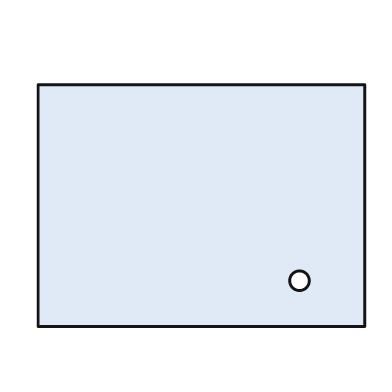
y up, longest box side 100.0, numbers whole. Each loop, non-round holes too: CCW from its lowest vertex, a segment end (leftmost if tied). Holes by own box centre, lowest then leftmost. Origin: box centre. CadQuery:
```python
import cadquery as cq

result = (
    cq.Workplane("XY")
    .moveTo(-50.0, -37.0)
    .lineTo(50.0, -37.0)
    .lineTo(50.0, 37.0)
    .lineTo(-50.0, 37.0)
    .close()
    .moveTo(30.0, -23.0)
    .circle(3.0)
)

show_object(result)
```